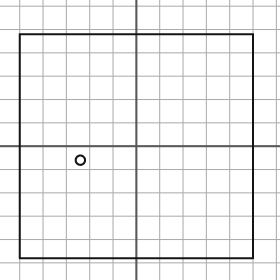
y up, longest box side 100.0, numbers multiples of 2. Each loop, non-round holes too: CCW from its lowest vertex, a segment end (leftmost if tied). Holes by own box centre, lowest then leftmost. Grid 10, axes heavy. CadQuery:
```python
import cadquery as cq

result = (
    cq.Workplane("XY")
    .moveTo(-50.0, -48.0)
    .lineTo(50.0, -48.0)
    .lineTo(50.0, 48.0)
    .lineTo(-50.0, 48.0)
    .close()
    .moveTo(-24.0, -6.0)
    .circle(2.0)
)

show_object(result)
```